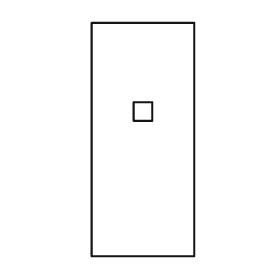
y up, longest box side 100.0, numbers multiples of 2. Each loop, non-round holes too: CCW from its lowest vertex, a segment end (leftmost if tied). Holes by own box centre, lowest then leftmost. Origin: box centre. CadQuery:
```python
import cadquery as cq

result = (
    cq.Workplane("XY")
    .moveTo(-22.0, -50.0)
    .lineTo(22.0, -50.0)
    .lineTo(22.0, 50.0)
    .lineTo(-22.0, 50.0)
    .close()
    .moveTo(-4.0, 8.0)
    .lineTo(4.0, 8.0)
    .lineTo(4.0, 16.0)
    .lineTo(-4.0, 16.0)
    .close()
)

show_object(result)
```